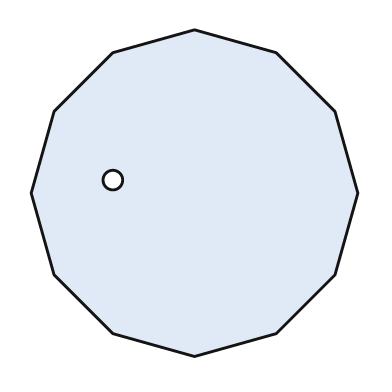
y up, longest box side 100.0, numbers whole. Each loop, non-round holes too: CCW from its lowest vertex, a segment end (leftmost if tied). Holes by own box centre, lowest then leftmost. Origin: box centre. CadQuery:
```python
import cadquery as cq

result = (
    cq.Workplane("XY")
    .moveTo(0.0, -50.0)
    .lineTo(25.0, -43.0)
    .lineTo(43.0, -25.0)
    .lineTo(50.0, 0.0)
    .lineTo(43.0, 25.0)
    .lineTo(25.0, 43.0)
    .lineTo(0.0, 50.0)
    .lineTo(-25.0, 43.0)
    .lineTo(-43.0, 25.0)
    .lineTo(-50.0, 0.0)
    .lineTo(-43.0, -25.0)
    .lineTo(-25.0, -43.0)
    .close()
    .moveTo(-25.0, 4.0)
    .circle(3.0)
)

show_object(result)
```